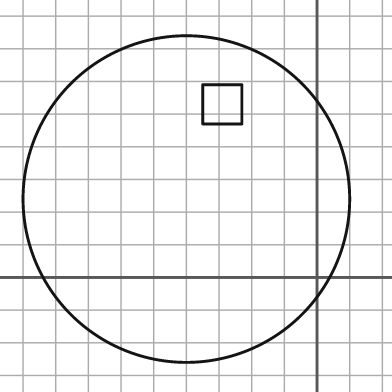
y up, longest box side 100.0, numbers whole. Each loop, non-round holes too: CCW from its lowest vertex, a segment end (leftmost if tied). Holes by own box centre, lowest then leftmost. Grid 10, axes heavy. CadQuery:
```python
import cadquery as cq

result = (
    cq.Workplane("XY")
    .moveTo(-40.0, 24.0)
    .circle(50.0)
    .moveTo(-35.0, 47.0)
    .lineTo(-23.0, 47.0)
    .lineTo(-23.0, 59.0)
    .lineTo(-35.0, 59.0)
    .close()
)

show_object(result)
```